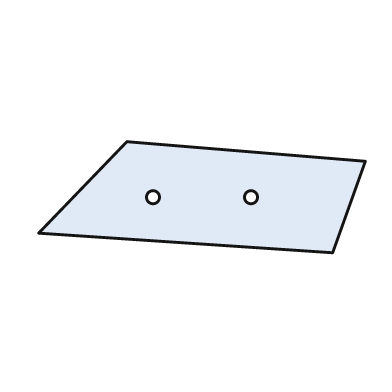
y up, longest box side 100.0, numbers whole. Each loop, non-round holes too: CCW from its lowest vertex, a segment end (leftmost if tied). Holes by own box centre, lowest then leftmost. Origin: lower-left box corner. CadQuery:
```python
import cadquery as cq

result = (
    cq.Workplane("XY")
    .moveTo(90.0, 0.0)
    .lineTo(100.0, 28.0)
    .lineTo(27.0, 34.0)
    .lineTo(0.0, 6.0)
    .close()
    .moveTo(35.0, 17.0)
    .circle(2.0)
    .moveTo(65.0, 17.0)
    .circle(2.0)
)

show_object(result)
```